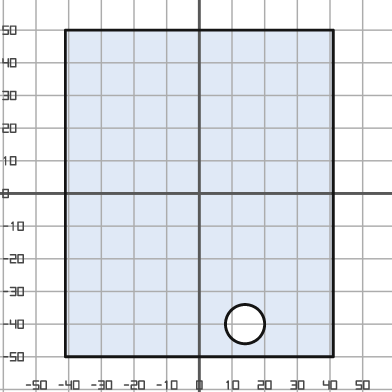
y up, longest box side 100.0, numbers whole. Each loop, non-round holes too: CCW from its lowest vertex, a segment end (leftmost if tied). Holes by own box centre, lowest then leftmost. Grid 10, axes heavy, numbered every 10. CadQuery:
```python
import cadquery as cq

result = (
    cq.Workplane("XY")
    .moveTo(-41.0, -50.0)
    .lineTo(41.0, -50.0)
    .lineTo(41.0, 50.0)
    .lineTo(-41.0, 50.0)
    .close()
    .moveTo(14.0, -40.0)
    .circle(6.0)
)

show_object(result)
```